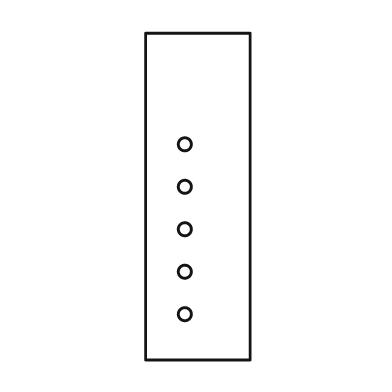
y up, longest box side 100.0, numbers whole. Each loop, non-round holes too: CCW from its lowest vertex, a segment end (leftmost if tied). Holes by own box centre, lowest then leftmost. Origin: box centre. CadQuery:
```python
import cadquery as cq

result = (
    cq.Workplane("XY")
    .moveTo(-16.0, -50.0)
    .lineTo(16.0, -50.0)
    .lineTo(16.0, 50.0)
    .lineTo(-16.0, 50.0)
    .close()
    .moveTo(-4.0, -36.0)
    .circle(2.0)
    .moveTo(-4.0, -23.0)
    .circle(2.0)
    .moveTo(-4.0, -10.0)
    .circle(2.0)
    .moveTo(-4.0, 3.0)
    .circle(2.0)
    .moveTo(-4.0, 16.0)
    .circle(2.0)
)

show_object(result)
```